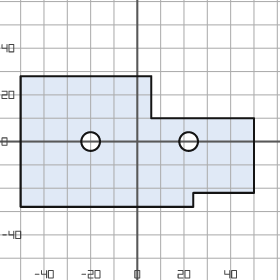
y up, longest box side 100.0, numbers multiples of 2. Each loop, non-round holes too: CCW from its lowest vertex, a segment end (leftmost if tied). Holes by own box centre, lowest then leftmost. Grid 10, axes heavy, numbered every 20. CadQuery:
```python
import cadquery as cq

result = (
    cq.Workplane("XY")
    .moveTo(-50.0, -28.0)
    .lineTo(24.0, -28.0)
    .lineTo(24.0, -22.0)
    .lineTo(50.0, -22.0)
    .lineTo(50.0, 10.0)
    .lineTo(6.0, 10.0)
    .lineTo(6.0, 28.0)
    .lineTo(-50.0, 28.0)
    .close()
    .moveTo(-20.0, 0.0)
    .circle(4.0)
    .moveTo(22.0, 0.0)
    .circle(4.0)
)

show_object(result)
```